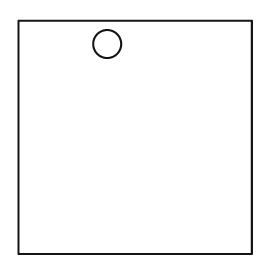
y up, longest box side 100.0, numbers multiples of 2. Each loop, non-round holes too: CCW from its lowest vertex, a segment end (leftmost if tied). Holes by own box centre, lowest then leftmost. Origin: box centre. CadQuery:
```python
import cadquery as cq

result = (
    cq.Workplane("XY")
    .moveTo(-50.0, -50.0)
    .lineTo(50.0, -50.0)
    .lineTo(50.0, 50.0)
    .lineTo(-50.0, 50.0)
    .close()
    .moveTo(-12.0, 40.0)
    .circle(6.0)
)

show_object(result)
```